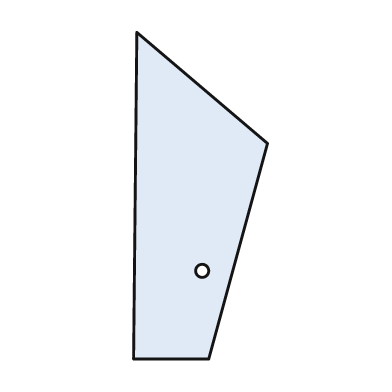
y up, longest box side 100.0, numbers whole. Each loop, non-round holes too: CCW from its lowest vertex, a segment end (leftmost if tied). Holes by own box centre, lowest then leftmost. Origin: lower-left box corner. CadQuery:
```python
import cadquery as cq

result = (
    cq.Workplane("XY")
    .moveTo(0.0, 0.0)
    .lineTo(23.0, 0.0)
    .lineTo(41.0, 66.0)
    .lineTo(1.0, 100.0)
    .close()
    .moveTo(21.0, 27.0)
    .circle(2.0)
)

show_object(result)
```